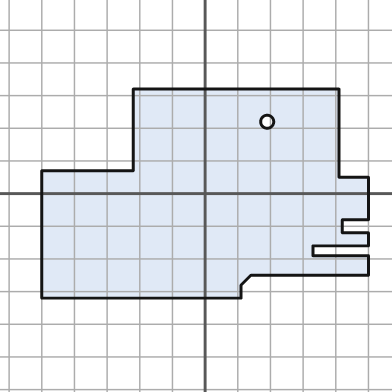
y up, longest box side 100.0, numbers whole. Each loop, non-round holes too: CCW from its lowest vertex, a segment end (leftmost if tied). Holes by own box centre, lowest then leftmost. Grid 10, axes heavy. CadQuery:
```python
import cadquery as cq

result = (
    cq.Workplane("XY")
    .moveTo(-50.0, -32.0)
    .lineTo(11.0, -32.0)
    .lineTo(11.0, -28.0)
    .lineTo(14.0, -25.0)
    .lineTo(50.0, -25.0)
    .lineTo(50.0, -19.0)
    .lineTo(33.0, -19.0)
    .lineTo(33.0, -16.0)
    .lineTo(50.0, -16.0)
    .lineTo(50.0, -12.0)
    .lineTo(42.0, -12.0)
    .lineTo(42.0, -8.0)
    .lineTo(50.0, -8.0)
    .lineTo(50.0, 5.0)
    .lineTo(41.0, 5.0)
    .lineTo(41.0, 32.0)
    .lineTo(-22.0, 32.0)
    .lineTo(-22.0, 7.0)
    .lineTo(-50.0, 7.0)
    .close()
    .moveTo(19.0, 22.0)
    .circle(2.0)
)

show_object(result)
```